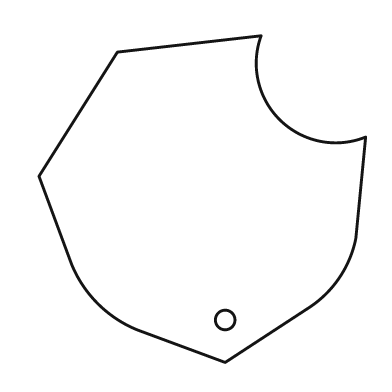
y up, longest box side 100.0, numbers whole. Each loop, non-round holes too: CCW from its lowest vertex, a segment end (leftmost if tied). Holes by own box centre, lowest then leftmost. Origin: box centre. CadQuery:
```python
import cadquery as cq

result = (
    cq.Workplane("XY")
    .moveTo(7.0, -50.0)
    .lineTo(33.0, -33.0)
    .threePointArc((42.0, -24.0), (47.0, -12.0))
    .lineTo(50.0, 19.0)
    .threePointArc((24.0, 24.0), (18.0, 50.0))
    .lineTo(-26.0, 45.0)
    .lineTo(-50.0, 7.0)
    .lineTo(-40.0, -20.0)
    .threePointArc((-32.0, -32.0), (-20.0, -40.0))
    .close()
    .moveTo(7.0, -37.0)
    .circle(3.0)
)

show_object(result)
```